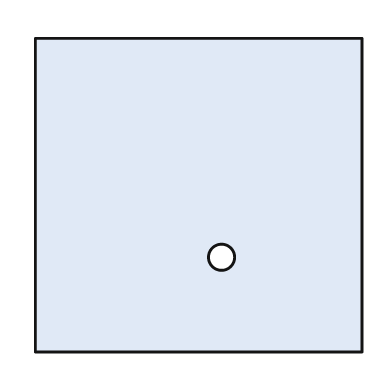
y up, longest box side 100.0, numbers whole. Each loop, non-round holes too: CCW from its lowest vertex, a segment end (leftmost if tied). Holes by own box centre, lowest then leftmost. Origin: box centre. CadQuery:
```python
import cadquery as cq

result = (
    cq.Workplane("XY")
    .moveTo(-50.0, -48.0)
    .lineTo(50.0, -48.0)
    .lineTo(50.0, 48.0)
    .lineTo(-50.0, 48.0)
    .close()
    .moveTo(7.0, -19.0)
    .circle(4.0)
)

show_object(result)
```